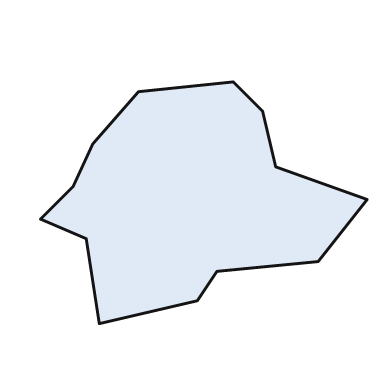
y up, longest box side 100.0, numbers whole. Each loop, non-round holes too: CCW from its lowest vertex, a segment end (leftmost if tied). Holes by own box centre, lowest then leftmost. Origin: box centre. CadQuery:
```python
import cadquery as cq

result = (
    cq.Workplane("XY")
    .moveTo(-32.0, -37.0)
    .lineTo(-2.0, -30.0)
    .lineTo(4.0, -21.0)
    .lineTo(35.0, -18.0)
    .lineTo(50.0, 1.0)
    .lineTo(22.0, 11.0)
    .lineTo(18.0, 28.0)
    .lineTo(9.0, 37.0)
    .lineTo(-20.0, 34.0)
    .lineTo(-34.0, 18.0)
    .lineTo(-40.0, 5.0)
    .lineTo(-50.0, -5.0)
    .lineTo(-36.0, -11.0)
    .close()
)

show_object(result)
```